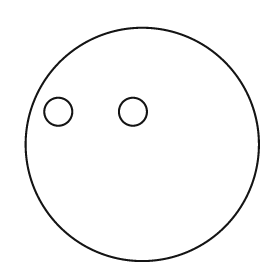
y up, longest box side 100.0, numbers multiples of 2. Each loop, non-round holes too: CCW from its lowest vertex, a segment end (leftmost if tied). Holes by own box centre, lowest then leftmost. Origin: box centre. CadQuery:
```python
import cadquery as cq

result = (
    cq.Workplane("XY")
    .moveTo(0.0, 0.0)
    .circle(50.0)
    .moveTo(-36.0, 14.0)
    .circle(6.0)
    .moveTo(-4.0, 14.0)
    .circle(6.0)
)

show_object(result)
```